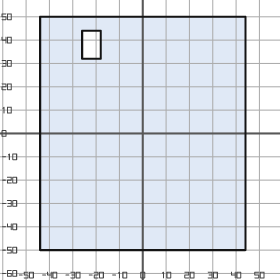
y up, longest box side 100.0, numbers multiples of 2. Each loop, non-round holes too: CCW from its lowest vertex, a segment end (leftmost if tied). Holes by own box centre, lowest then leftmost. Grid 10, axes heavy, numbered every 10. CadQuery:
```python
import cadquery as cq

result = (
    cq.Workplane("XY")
    .moveTo(-44.0, -50.0)
    .lineTo(44.0, -50.0)
    .lineTo(44.0, 50.0)
    .lineTo(-44.0, 50.0)
    .close()
    .moveTo(-26.0, 32.0)
    .lineTo(-18.0, 32.0)
    .lineTo(-18.0, 44.0)
    .lineTo(-26.0, 44.0)
    .close()
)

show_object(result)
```